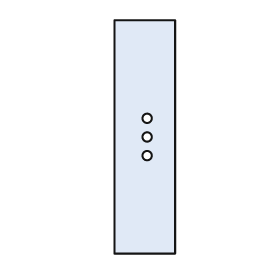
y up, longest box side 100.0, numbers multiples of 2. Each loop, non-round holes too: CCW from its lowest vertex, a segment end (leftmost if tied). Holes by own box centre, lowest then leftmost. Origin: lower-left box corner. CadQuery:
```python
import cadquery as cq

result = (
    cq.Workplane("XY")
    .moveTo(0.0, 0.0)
    .lineTo(26.0, 0.0)
    .lineTo(26.0, 100.0)
    .lineTo(0.0, 100.0)
    .close()
    .moveTo(14.0, 42.0)
    .circle(2.0)
    .moveTo(14.0, 50.0)
    .circle(2.0)
    .moveTo(14.0, 58.0)
    .circle(2.0)
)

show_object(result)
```